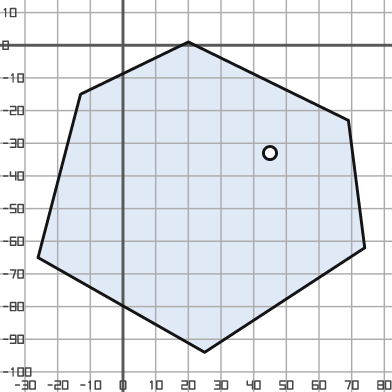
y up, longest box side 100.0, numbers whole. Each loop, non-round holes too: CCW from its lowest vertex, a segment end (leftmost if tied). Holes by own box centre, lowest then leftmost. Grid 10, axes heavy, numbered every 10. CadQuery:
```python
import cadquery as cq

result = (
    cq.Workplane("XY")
    .moveTo(25.0, -94.0)
    .lineTo(74.0, -62.0)
    .lineTo(69.0, -23.0)
    .lineTo(20.0, 1.0)
    .lineTo(-13.0, -15.0)
    .lineTo(-26.0, -65.0)
    .close()
    .moveTo(45.0, -33.0)
    .circle(2.0)
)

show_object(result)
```